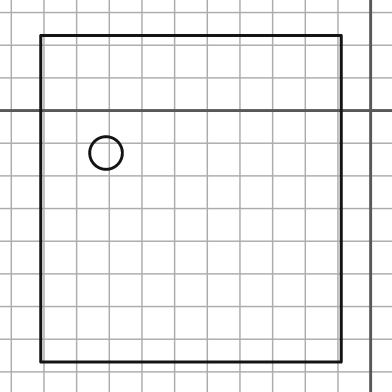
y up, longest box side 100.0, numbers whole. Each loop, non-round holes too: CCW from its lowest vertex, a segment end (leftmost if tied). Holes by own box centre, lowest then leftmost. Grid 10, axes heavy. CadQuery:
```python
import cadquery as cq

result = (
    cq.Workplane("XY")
    .moveTo(-101.0, -77.0)
    .lineTo(-9.0, -77.0)
    .lineTo(-9.0, 23.0)
    .lineTo(-101.0, 23.0)
    .close()
    .moveTo(-81.0, -13.0)
    .circle(5.0)
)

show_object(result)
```